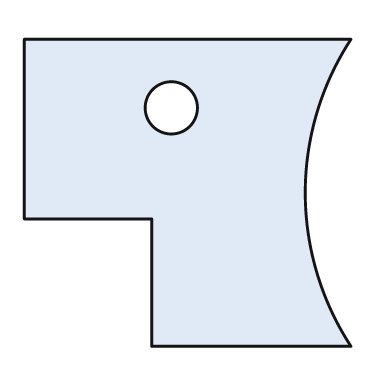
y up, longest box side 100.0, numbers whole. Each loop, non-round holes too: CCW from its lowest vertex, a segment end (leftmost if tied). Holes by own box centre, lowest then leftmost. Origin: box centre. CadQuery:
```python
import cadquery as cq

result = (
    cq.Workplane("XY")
    .moveTo(-11.0, -47.0)
    .lineTo(50.0, -47.0)
    .threePointArc((36.0, 0.0), (50.0, 47.0))
    .lineTo(-50.0, 47.0)
    .lineTo(-50.0, -8.0)
    .lineTo(-11.0, -8.0)
    .close()
    .moveTo(-5.0, 26.0)
    .circle(8.0)
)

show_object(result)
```